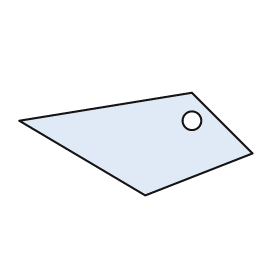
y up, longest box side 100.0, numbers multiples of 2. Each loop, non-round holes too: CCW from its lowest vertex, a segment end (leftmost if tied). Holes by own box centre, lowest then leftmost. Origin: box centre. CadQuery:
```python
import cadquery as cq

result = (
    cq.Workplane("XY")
    .moveTo(4.0, -22.0)
    .lineTo(50.0, -4.0)
    .lineTo(24.0, 22.0)
    .lineTo(-50.0, 10.0)
    .close()
    .moveTo(24.0, 10.0)
    .circle(4.0)
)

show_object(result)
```